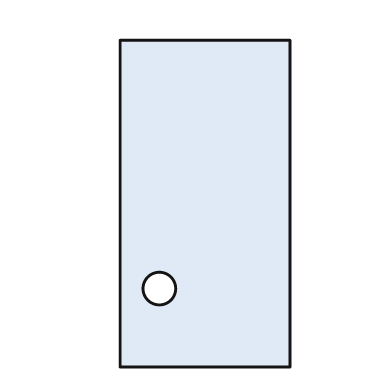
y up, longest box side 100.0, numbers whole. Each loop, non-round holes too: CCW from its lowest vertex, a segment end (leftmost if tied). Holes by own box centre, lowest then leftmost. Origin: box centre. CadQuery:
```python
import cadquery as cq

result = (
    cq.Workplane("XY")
    .moveTo(-26.0, -50.0)
    .lineTo(26.0, -50.0)
    .lineTo(26.0, 50.0)
    .lineTo(-26.0, 50.0)
    .close()
    .moveTo(-14.0, -26.0)
    .circle(5.0)
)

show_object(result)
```